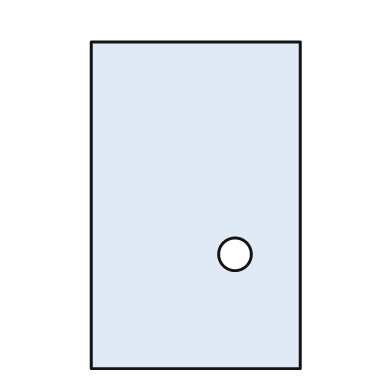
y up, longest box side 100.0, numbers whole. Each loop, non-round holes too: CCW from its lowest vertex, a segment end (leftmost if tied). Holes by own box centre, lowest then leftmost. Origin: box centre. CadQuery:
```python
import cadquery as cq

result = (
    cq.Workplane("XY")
    .moveTo(-32.0, -50.0)
    .lineTo(32.0, -50.0)
    .lineTo(32.0, 50.0)
    .lineTo(-32.0, 50.0)
    .close()
    .moveTo(12.0, -15.0)
    .circle(5.0)
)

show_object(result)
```